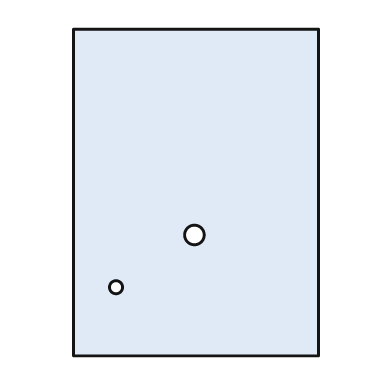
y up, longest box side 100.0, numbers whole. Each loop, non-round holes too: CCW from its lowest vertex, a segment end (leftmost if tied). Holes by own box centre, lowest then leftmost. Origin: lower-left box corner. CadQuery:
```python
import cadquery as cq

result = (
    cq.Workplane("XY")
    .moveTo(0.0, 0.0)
    .lineTo(75.0, 0.0)
    .lineTo(75.0, 100.0)
    .lineTo(0.0, 100.0)
    .close()
    .moveTo(13.0, 21.0)
    .circle(2.0)
    .moveTo(37.0, 37.0)
    .circle(3.0)
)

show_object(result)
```